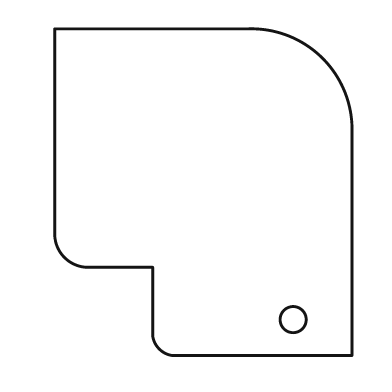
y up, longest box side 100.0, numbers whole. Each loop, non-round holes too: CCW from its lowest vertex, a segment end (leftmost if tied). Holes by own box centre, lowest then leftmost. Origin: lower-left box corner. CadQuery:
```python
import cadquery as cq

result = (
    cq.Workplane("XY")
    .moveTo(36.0, 0.0)
    .lineTo(91.0, 0.0)
    .lineTo(91.0, 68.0)
    .threePointArc((82.0, 91.0), (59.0, 100.0))
    .lineTo(0.0, 100.0)
    .lineTo(0.0, 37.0)
    .threePointArc((3.0, 30.0), (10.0, 27.0))
    .lineTo(30.0, 27.0)
    .lineTo(30.0, 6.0)
    .threePointArc((32.0, 2.0), (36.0, 0.0))
    .close()
    .moveTo(73.0, 11.0)
    .circle(4.0)
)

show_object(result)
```